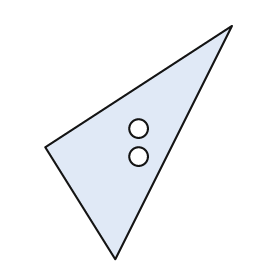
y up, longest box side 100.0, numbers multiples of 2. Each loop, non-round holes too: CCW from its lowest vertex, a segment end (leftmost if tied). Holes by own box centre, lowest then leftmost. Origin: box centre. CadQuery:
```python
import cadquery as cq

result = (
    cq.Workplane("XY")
    .moveTo(-10.0, -50.0)
    .lineTo(40.0, 50.0)
    .lineTo(-40.0, -2.0)
    .close()
    .moveTo(0.0, -6.0)
    .circle(4.0)
    .moveTo(0.0, 6.0)
    .circle(4.0)
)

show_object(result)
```